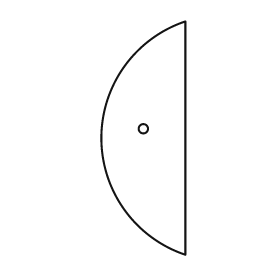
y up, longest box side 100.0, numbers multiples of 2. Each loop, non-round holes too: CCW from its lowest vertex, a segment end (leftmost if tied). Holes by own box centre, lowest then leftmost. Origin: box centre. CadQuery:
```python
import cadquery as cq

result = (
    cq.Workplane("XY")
    .moveTo(18.0, -50.0)
    .lineTo(18.0, 50.0)
    .threePointArc((-18.0, 0.0), (18.0, -50.0))
    .close()
    .moveTo(0.0, 4.0)
    .circle(2.0)
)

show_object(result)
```